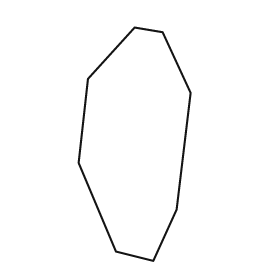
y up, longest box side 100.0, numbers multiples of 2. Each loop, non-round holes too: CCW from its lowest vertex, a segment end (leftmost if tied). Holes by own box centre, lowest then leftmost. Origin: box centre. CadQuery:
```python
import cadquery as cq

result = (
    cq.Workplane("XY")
    .moveTo(8.0, -50.0)
    .lineTo(18.0, -28.0)
    .lineTo(24.0, 22.0)
    .lineTo(12.0, 48.0)
    .lineTo(0.0, 50.0)
    .lineTo(-20.0, 28.0)
    .lineTo(-24.0, -8.0)
    .lineTo(-8.0, -46.0)
    .close()
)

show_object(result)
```